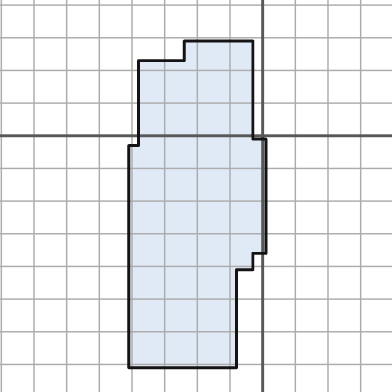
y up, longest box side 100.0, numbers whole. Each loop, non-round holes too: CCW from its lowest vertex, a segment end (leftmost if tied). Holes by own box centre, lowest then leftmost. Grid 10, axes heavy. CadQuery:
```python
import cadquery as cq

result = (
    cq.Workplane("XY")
    .moveTo(-41.0, -71.0)
    .lineTo(-8.0, -71.0)
    .lineTo(-8.0, -41.0)
    .lineTo(-3.0, -41.0)
    .lineTo(-3.0, -36.0)
    .lineTo(1.0, -36.0)
    .lineTo(1.0, -1.0)
    .lineTo(-3.0, -1.0)
    .lineTo(-3.0, 29.0)
    .lineTo(-24.0, 29.0)
    .lineTo(-24.0, 23.0)
    .lineTo(-38.0, 23.0)
    .lineTo(-38.0, -3.0)
    .lineTo(-41.0, -3.0)
    .close()
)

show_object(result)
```